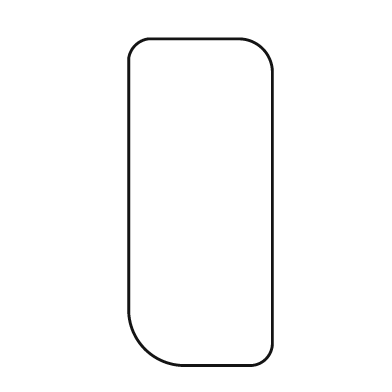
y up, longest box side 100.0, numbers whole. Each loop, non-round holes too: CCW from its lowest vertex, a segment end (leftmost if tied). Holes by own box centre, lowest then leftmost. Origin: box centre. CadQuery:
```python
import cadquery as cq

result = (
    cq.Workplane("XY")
    .moveTo(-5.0, -50.0)
    .lineTo(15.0, -50.0)
    .threePointArc((20.0, -48.0), (22.0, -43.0))
    .lineTo(22.0, 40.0)
    .threePointArc((19.0, 47.0), (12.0, 50.0))
    .lineTo(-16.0, 50.0)
    .threePointArc((-20.0, 48.0), (-22.0, 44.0))
    .lineTo(-22.0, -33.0)
    .threePointArc((-17.0, -45.0), (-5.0, -50.0))
    .close()
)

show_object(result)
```